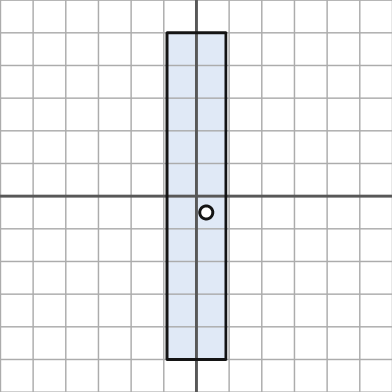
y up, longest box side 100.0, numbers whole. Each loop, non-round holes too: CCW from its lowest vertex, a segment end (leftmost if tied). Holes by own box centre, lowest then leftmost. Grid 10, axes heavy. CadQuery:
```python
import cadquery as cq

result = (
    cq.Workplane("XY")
    .moveTo(-9.0, -50.0)
    .lineTo(9.0, -50.0)
    .lineTo(9.0, 50.0)
    .lineTo(-9.0, 50.0)
    .close()
    .moveTo(3.0, -5.0)
    .circle(2.0)
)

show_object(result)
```